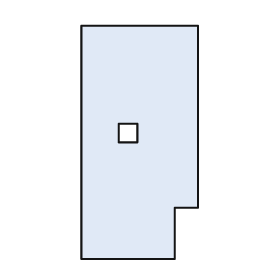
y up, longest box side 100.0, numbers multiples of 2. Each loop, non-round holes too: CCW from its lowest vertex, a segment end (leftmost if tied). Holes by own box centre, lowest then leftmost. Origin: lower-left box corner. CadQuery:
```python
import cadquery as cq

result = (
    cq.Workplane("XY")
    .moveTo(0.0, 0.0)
    .lineTo(40.0, 0.0)
    .lineTo(40.0, 22.0)
    .lineTo(50.0, 22.0)
    .lineTo(50.0, 100.0)
    .lineTo(0.0, 100.0)
    .close()
    .moveTo(16.0, 50.0)
    .lineTo(24.0, 50.0)
    .lineTo(24.0, 58.0)
    .lineTo(16.0, 58.0)
    .close()
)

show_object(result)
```